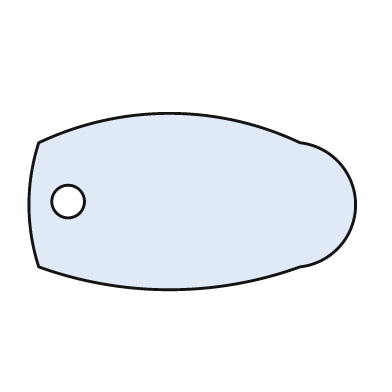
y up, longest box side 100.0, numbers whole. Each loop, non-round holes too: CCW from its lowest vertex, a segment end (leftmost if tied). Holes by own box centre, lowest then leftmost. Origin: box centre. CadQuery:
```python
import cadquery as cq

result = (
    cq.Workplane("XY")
    .moveTo(-47.0, -20.0)
    .threePointArc((-7.0, -27.0), (33.0, -20.0))
    .threePointArc((50.0, -1.0), (33.0, 18.0))
    .threePointArc((-7.0, 27.0), (-47.0, 18.0))
    .threePointArc((-50.0, -1.0), (-47.0, -20.0))
    .close()
    .moveTo(-38.0, 0.0)
    .circle(5.0)
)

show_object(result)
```